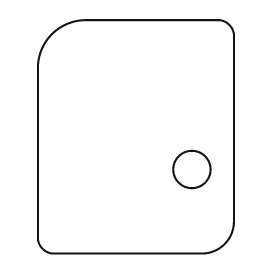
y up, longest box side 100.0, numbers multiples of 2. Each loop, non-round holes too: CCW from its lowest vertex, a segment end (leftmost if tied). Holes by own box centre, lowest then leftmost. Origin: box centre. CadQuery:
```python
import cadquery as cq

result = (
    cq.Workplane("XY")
    .moveTo(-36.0, -50.0)
    .lineTo(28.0, -50.0)
    .threePointArc((38.0, -46.0), (42.0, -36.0))
    .lineTo(42.0, 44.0)
    .threePointArc((40.0, 48.0), (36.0, 50.0))
    .lineTo(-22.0, 50.0)
    .threePointArc((-36.0, 44.0), (-42.0, 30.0))
    .lineTo(-42.0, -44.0)
    .threePointArc((-40.0, -48.0), (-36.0, -50.0))
    .close()
    .moveTo(24.0, -14.0)
    .circle(8.0)
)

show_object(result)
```